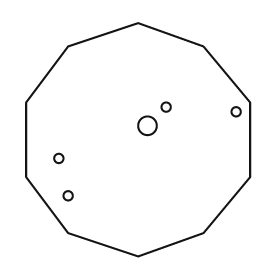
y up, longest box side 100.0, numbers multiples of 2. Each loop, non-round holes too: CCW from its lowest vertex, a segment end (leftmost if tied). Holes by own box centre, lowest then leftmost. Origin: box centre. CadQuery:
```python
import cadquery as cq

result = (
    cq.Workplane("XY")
    .moveTo(0.0, -50.0)
    .lineTo(28.0, -40.0)
    .lineTo(48.0, -16.0)
    .lineTo(48.0, 16.0)
    .lineTo(28.0, 40.0)
    .lineTo(0.0, 50.0)
    .lineTo(-30.0, 40.0)
    .lineTo(-48.0, 16.0)
    .lineTo(-48.0, -16.0)
    .lineTo(-30.0, -40.0)
    .close()
    .moveTo(-30.0, -24.0)
    .circle(2.0)
    .moveTo(-34.0, -8.0)
    .circle(2.0)
    .moveTo(4.0, 6.0)
    .circle(4.0)
    .moveTo(42.0, 12.0)
    .circle(2.0)
    .moveTo(12.0, 14.0)
    .circle(2.0)
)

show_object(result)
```